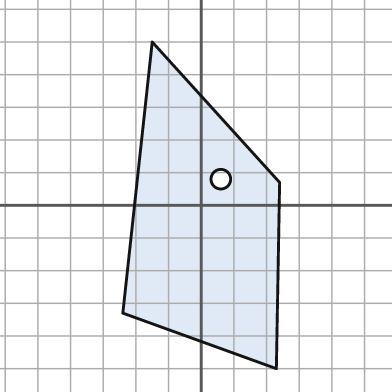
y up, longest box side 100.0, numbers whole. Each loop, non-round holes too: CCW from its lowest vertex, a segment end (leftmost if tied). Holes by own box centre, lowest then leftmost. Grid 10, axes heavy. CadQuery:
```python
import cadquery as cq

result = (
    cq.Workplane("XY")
    .moveTo(23.0, -50.0)
    .lineTo(24.0, 7.0)
    .lineTo(-15.0, 50.0)
    .lineTo(-24.0, -33.0)
    .close()
    .moveTo(6.0, 8.0)
    .circle(3.0)
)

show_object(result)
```